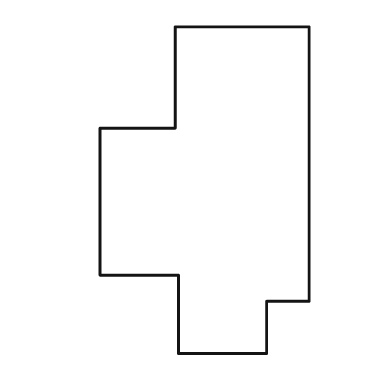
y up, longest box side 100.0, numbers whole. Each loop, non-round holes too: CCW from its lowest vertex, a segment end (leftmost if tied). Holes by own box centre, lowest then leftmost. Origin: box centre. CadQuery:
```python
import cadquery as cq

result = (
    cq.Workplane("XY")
    .moveTo(-8.0, -50.0)
    .lineTo(19.0, -50.0)
    .lineTo(19.0, -34.0)
    .lineTo(32.0, -34.0)
    .lineTo(32.0, 50.0)
    .lineTo(-9.0, 50.0)
    .lineTo(-9.0, 19.0)
    .lineTo(-32.0, 19.0)
    .lineTo(-32.0, -26.0)
    .lineTo(-8.0, -26.0)
    .close()
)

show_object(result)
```